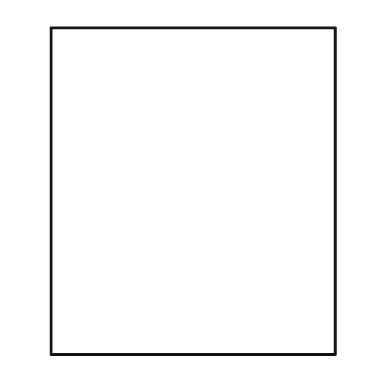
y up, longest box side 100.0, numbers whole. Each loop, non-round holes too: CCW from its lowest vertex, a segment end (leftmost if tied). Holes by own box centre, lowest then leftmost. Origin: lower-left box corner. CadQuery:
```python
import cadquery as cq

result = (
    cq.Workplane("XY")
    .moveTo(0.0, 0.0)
    .lineTo(87.0, 0.0)
    .lineTo(87.0, 100.0)
    .lineTo(0.0, 100.0)
    .close()
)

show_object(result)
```